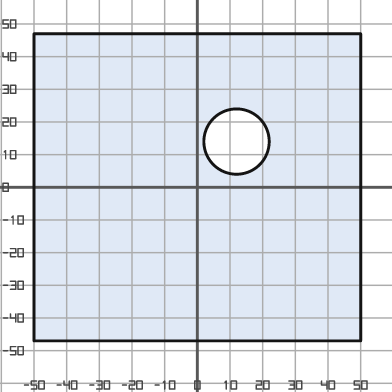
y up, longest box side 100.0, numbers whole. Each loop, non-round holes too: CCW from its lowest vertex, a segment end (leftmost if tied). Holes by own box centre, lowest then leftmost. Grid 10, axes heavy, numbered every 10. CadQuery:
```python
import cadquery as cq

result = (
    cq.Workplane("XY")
    .moveTo(-50.0, -47.0)
    .lineTo(50.0, -47.0)
    .lineTo(50.0, 47.0)
    .lineTo(-50.0, 47.0)
    .close()
    .moveTo(12.0, 14.0)
    .circle(10.0)
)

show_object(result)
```